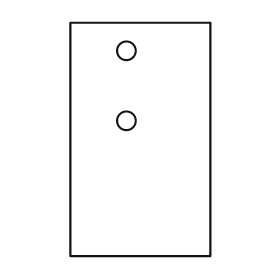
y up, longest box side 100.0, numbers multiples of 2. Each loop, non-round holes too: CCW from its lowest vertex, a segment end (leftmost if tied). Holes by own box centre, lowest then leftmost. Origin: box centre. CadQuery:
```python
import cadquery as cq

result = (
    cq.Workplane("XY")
    .moveTo(-30.0, -50.0)
    .lineTo(30.0, -50.0)
    .lineTo(30.0, 50.0)
    .lineTo(-30.0, 50.0)
    .close()
    .moveTo(-6.0, 8.0)
    .circle(4.0)
    .moveTo(-6.0, 38.0)
    .circle(4.0)
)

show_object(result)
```